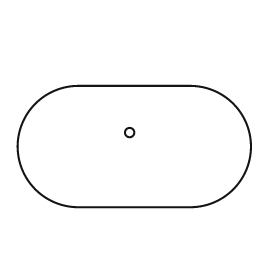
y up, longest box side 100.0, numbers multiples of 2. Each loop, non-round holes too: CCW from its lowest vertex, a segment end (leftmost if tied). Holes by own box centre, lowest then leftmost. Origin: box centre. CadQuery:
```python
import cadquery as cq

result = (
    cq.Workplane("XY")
    .moveTo(-24.0, -26.0)
    .lineTo(24.0, -26.0)
    .threePointArc((50.0, 0.0), (24.0, 26.0))
    .lineTo(-24.0, 26.0)
    .threePointArc((-50.0, 0.0), (-24.0, -26.0))
    .close()
    .moveTo(-2.0, 6.0)
    .circle(2.0)
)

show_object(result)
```